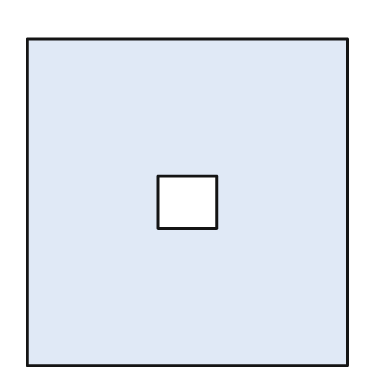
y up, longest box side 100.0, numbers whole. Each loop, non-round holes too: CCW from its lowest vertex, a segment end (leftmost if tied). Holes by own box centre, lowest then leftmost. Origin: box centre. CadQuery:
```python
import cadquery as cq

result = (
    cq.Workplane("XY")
    .moveTo(-49.0, -50.0)
    .lineTo(49.0, -50.0)
    .lineTo(49.0, 50.0)
    .lineTo(-49.0, 50.0)
    .close()
    .moveTo(-9.0, -8.0)
    .lineTo(9.0, -8.0)
    .lineTo(9.0, 8.0)
    .lineTo(-9.0, 8.0)
    .close()
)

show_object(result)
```